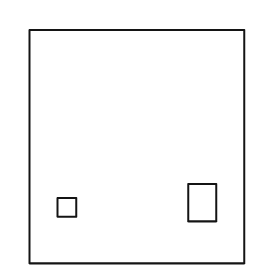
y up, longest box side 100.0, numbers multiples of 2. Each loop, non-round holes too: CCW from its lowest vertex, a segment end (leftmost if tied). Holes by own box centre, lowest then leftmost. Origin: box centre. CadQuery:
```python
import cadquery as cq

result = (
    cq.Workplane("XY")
    .moveTo(-46.0, -50.0)
    .lineTo(46.0, -50.0)
    .lineTo(46.0, 50.0)
    .lineTo(-46.0, 50.0)
    .close()
    .moveTo(-34.0, -30.0)
    .lineTo(-26.0, -30.0)
    .lineTo(-26.0, -22.0)
    .lineTo(-34.0, -22.0)
    .close()
    .moveTo(22.0, -32.0)
    .lineTo(34.0, -32.0)
    .lineTo(34.0, -16.0)
    .lineTo(22.0, -16.0)
    .close()
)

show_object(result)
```